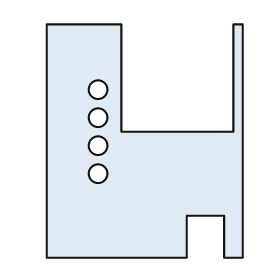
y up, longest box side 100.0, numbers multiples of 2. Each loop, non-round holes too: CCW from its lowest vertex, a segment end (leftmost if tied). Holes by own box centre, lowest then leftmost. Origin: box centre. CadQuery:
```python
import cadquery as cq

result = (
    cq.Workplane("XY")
    .moveTo(-42.0, -50.0)
    .lineTo(18.0, -50.0)
    .lineTo(18.0, -32.0)
    .lineTo(34.0, -32.0)
    .lineTo(34.0, -50.0)
    .lineTo(42.0, -50.0)
    .lineTo(42.0, 50.0)
    .lineTo(38.0, 50.0)
    .lineTo(38.0, 4.0)
    .lineTo(-10.0, 4.0)
    .lineTo(-10.0, 50.0)
    .lineTo(-42.0, 50.0)
    .close()
    .moveTo(-20.0, -14.0)
    .circle(4.0)
    .moveTo(-20.0, -2.0)
    .circle(4.0)
    .moveTo(-20.0, 10.0)
    .circle(4.0)
    .moveTo(-20.0, 22.0)
    .circle(4.0)
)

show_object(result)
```